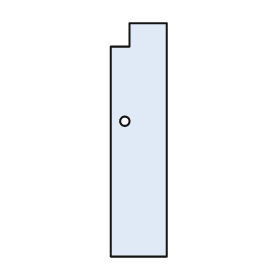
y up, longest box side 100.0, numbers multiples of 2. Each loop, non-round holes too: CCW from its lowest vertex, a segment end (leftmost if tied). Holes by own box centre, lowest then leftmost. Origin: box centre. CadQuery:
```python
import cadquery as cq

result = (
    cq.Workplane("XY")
    .moveTo(-12.0, -50.0)
    .lineTo(12.0, -50.0)
    .lineTo(12.0, 50.0)
    .lineTo(-4.0, 50.0)
    .lineTo(-4.0, 40.0)
    .lineTo(-12.0, 40.0)
    .close()
    .moveTo(-6.0, 8.0)
    .circle(2.0)
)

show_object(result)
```